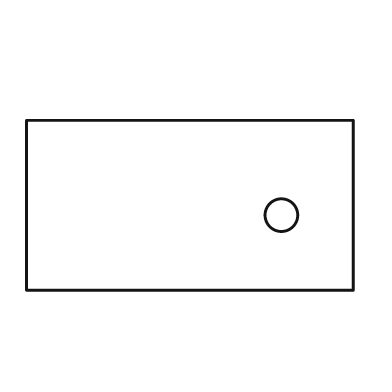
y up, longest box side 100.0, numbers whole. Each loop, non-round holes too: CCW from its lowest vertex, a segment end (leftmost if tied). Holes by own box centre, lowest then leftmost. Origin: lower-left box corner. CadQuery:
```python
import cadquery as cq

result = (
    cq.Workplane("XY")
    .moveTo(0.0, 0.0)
    .lineTo(100.0, 0.0)
    .lineTo(100.0, 52.0)
    .lineTo(0.0, 52.0)
    .close()
    .moveTo(78.0, 23.0)
    .circle(5.0)
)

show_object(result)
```